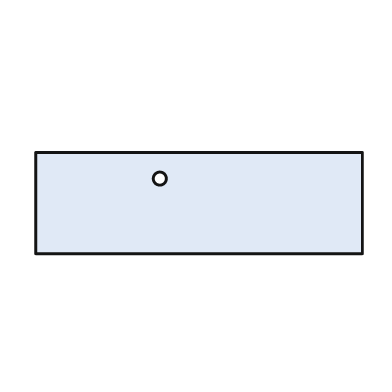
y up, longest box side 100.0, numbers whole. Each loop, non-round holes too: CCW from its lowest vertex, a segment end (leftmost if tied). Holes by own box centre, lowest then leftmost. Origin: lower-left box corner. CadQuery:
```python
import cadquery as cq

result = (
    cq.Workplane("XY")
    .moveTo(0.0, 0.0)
    .lineTo(100.0, 0.0)
    .lineTo(100.0, 31.0)
    .lineTo(0.0, 31.0)
    .close()
    .moveTo(38.0, 23.0)
    .circle(2.0)
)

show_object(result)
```